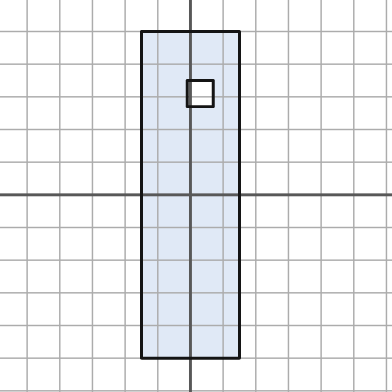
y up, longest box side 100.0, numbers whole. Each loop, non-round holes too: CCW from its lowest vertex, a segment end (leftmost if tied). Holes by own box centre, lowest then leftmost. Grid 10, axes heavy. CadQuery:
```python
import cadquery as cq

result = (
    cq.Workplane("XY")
    .moveTo(-15.0, -50.0)
    .lineTo(15.0, -50.0)
    .lineTo(15.0, 50.0)
    .lineTo(-15.0, 50.0)
    .close()
    .moveTo(-1.0, 27.0)
    .lineTo(7.0, 27.0)
    .lineTo(7.0, 35.0)
    .lineTo(-1.0, 35.0)
    .close()
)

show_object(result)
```